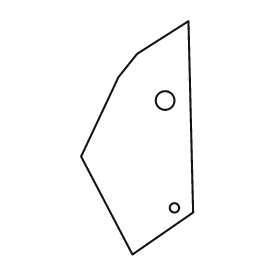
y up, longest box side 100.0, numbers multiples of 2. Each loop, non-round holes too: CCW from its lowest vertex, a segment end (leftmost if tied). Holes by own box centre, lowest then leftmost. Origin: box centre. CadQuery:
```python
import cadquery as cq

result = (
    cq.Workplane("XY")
    .moveTo(-2.0, -50.0)
    .lineTo(24.0, -32.0)
    .lineTo(22.0, 50.0)
    .lineTo(0.0, 36.0)
    .lineTo(-8.0, 26.0)
    .lineTo(-24.0, -8.0)
    .close()
    .moveTo(16.0, -30.0)
    .circle(2.0)
    .moveTo(12.0, 16.0)
    .circle(4.0)
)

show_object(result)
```